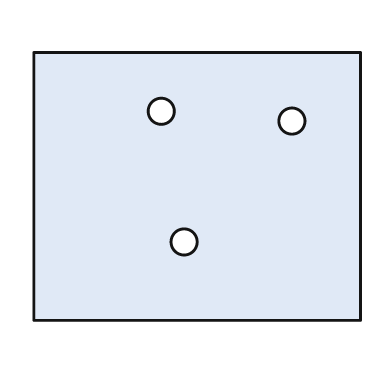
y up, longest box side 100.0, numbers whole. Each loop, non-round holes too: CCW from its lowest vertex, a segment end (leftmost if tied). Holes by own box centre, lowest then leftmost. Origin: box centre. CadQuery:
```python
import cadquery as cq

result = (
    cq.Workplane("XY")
    .moveTo(-50.0, -41.0)
    .lineTo(50.0, -41.0)
    .lineTo(50.0, 41.0)
    .lineTo(-50.0, 41.0)
    .close()
    .moveTo(-4.0, -17.0)
    .circle(4.0)
    .moveTo(29.0, 20.0)
    .circle(4.0)
    .moveTo(-11.0, 23.0)
    .circle(4.0)
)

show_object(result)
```